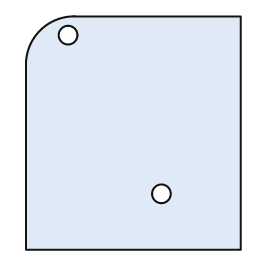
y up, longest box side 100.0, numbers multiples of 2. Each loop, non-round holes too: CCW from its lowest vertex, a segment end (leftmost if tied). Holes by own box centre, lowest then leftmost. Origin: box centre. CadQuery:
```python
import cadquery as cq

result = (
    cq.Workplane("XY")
    .moveTo(-46.0, -50.0)
    .lineTo(46.0, -50.0)
    .lineTo(46.0, 50.0)
    .lineTo(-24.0, 50.0)
    .threePointArc((-40.0, 44.0), (-46.0, 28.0))
    .close()
    .moveTo(12.0, -26.0)
    .circle(4.0)
    .moveTo(-28.0, 42.0)
    .circle(4.0)
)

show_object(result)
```